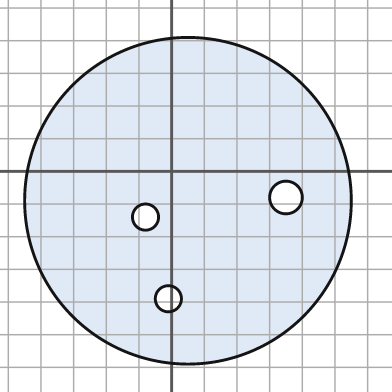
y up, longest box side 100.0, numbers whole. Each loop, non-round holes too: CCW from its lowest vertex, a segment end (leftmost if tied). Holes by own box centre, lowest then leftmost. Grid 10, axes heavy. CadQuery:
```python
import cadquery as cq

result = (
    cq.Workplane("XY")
    .moveTo(5.0, -9.0)
    .circle(50.0)
    .moveTo(-1.0, -39.0)
    .circle(4.0)
    .moveTo(-8.0, -14.0)
    .circle(4.0)
    .moveTo(35.0, -8.0)
    .circle(5.0)
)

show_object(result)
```